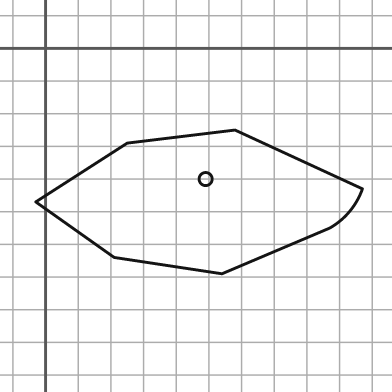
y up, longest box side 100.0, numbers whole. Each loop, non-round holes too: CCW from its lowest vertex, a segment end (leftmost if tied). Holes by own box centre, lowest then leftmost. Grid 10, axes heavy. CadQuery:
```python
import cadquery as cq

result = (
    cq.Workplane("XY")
    .moveTo(54.0, -69.0)
    .lineTo(87.0, -55.0)
    .threePointArc((93.0, -50.0), (97.0, -43.0))
    .lineTo(58.0, -25.0)
    .lineTo(25.0, -29.0)
    .lineTo(-3.0, -47.0)
    .lineTo(21.0, -64.0)
    .close()
    .moveTo(49.0, -40.0)
    .circle(2.0)
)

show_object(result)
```